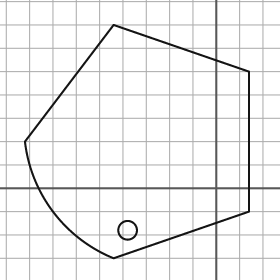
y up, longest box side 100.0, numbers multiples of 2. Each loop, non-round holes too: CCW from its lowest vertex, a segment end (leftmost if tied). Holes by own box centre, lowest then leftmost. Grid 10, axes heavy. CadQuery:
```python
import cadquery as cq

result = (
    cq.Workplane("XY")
    .moveTo(-44.0, -30.0)
    .lineTo(14.0, -10.0)
    .lineTo(14.0, 50.0)
    .lineTo(-44.0, 70.0)
    .lineTo(-82.0, 20.0)
    .threePointArc((-70.0, -10.0), (-44.0, -30.0))
    .close()
    .moveTo(-38.0, -18.0)
    .circle(4.0)
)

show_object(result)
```